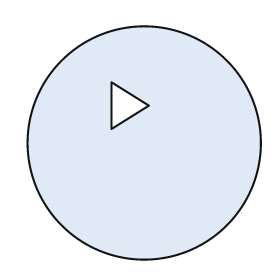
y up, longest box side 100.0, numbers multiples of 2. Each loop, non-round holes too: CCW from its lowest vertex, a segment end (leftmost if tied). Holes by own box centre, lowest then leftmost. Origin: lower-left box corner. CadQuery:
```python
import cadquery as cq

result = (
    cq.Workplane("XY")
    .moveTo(50.0, 50.0)
    .circle(50.0)
    .moveTo(36.0, 56.0)
    .lineTo(52.0, 66.0)
    .lineTo(36.0, 76.0)
    .close()
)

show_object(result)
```